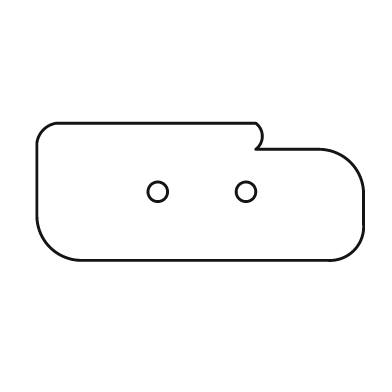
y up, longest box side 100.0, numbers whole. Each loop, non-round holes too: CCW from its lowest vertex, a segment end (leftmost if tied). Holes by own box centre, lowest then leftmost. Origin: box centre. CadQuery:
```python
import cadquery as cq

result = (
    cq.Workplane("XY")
    .moveTo(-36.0, -21.0)
    .lineTo(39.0, -21.0)
    .threePointArc((47.0, -18.0), (50.0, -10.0))
    .lineTo(50.0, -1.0)
    .threePointArc((46.0, 9.0), (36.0, 13.0))
    .lineTo(17.0, 13.0)
    .threePointArc((19.0, 17.0), (17.0, 21.0))
    .lineTo(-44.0, 21.0)
    .threePointArc((-48.0, 19.0), (-50.0, 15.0))
    .lineTo(-50.0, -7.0)
    .threePointArc((-46.0, -17.0), (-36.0, -21.0))
    .close()
    .moveTo(-13.0, 0.0)
    .circle(3.0)
    .moveTo(14.0, 0.0)
    .circle(3.0)
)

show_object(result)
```